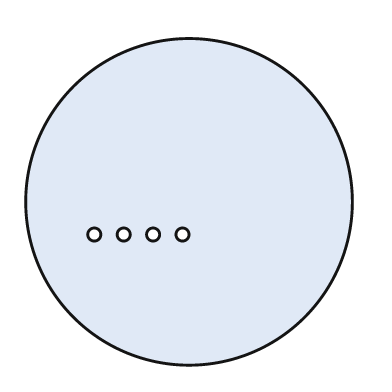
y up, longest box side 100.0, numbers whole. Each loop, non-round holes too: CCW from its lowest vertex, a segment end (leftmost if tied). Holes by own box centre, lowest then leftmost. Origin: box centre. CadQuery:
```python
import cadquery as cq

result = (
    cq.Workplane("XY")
    .moveTo(0.0, 0.0)
    .circle(50.0)
    .moveTo(-29.0, -10.0)
    .circle(2.0)
    .moveTo(-20.0, -10.0)
    .circle(2.0)
    .moveTo(-11.0, -10.0)
    .circle(2.0)
    .moveTo(-2.0, -10.0)
    .circle(2.0)
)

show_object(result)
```